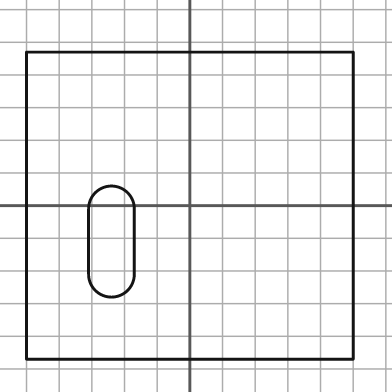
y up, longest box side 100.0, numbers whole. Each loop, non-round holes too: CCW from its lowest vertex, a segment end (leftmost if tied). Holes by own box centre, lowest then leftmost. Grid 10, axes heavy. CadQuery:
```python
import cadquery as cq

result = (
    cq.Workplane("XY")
    .moveTo(-50.0, -47.0)
    .lineTo(50.0, -47.0)
    .lineTo(50.0, 47.0)
    .lineTo(-50.0, 47.0)
    .close()
    .moveTo(-31.0, -21.0)
    .threePointArc((-24.0, -28.0), (-17.0, -21.0))
    .lineTo(-17.0, -1.0)
    .threePointArc((-24.0, 6.0), (-31.0, -1.0))
    .close()
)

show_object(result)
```